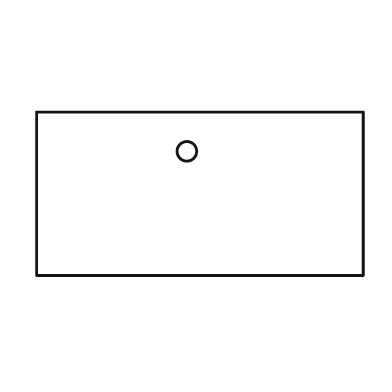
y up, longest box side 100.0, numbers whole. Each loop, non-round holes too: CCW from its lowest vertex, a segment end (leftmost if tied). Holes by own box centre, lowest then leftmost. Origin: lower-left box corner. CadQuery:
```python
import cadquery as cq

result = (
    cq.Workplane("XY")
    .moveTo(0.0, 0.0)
    .lineTo(100.0, 0.0)
    .lineTo(100.0, 50.0)
    .lineTo(0.0, 50.0)
    .close()
    .moveTo(46.0, 38.0)
    .circle(3.0)
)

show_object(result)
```